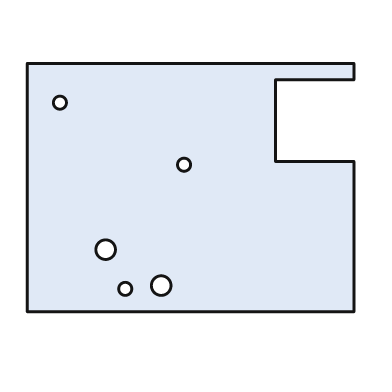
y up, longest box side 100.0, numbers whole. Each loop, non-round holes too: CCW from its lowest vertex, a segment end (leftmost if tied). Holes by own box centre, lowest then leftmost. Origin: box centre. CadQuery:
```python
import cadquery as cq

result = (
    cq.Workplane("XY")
    .moveTo(-50.0, -38.0)
    .lineTo(50.0, -38.0)
    .lineTo(50.0, 8.0)
    .lineTo(26.0, 8.0)
    .lineTo(26.0, 33.0)
    .lineTo(50.0, 33.0)
    .lineTo(50.0, 38.0)
    .lineTo(-50.0, 38.0)
    .close()
    .moveTo(-20.0, -31.0)
    .circle(2.0)
    .moveTo(-9.0, -30.0)
    .circle(3.0)
    .moveTo(-26.0, -19.0)
    .circle(3.0)
    .moveTo(-2.0, 7.0)
    .circle(2.0)
    .moveTo(-40.0, 26.0)
    .circle(2.0)
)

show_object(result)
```